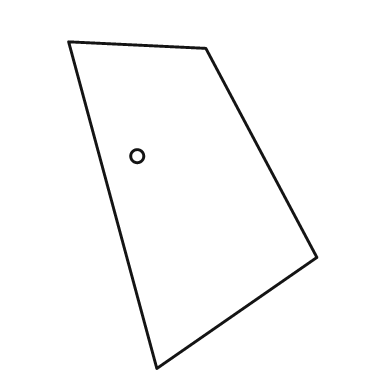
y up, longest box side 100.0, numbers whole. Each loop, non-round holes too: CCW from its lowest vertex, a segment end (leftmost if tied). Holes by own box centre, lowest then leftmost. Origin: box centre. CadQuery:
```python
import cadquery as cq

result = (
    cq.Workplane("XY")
    .moveTo(-11.0, -50.0)
    .lineTo(38.0, -16.0)
    .lineTo(4.0, 48.0)
    .lineTo(-38.0, 50.0)
    .close()
    .moveTo(-17.0, 15.0)
    .circle(2.0)
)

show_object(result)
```